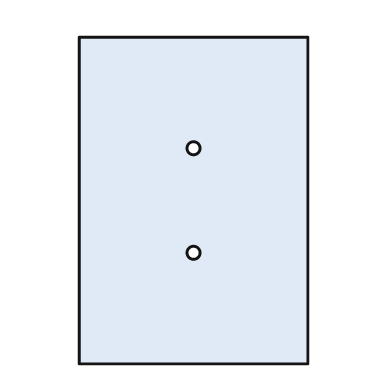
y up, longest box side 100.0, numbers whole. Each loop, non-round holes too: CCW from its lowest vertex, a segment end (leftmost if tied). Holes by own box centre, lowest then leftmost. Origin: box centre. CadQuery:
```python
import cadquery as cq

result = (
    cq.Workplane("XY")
    .moveTo(-35.0, -50.0)
    .lineTo(35.0, -50.0)
    .lineTo(35.0, 50.0)
    .lineTo(-35.0, 50.0)
    .close()
    .moveTo(0.0, -16.0)
    .circle(2.0)
    .moveTo(0.0, 16.0)
    .circle(2.0)
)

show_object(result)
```